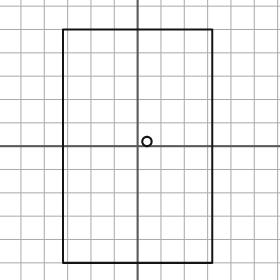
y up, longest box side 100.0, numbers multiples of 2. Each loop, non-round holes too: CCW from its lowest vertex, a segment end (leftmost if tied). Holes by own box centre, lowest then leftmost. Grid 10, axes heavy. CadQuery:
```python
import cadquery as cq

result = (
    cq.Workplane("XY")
    .moveTo(-32.0, -50.0)
    .lineTo(32.0, -50.0)
    .lineTo(32.0, 50.0)
    .lineTo(-32.0, 50.0)
    .close()
    .moveTo(4.0, 2.0)
    .circle(2.0)
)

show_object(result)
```